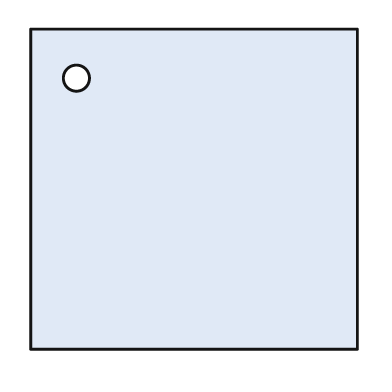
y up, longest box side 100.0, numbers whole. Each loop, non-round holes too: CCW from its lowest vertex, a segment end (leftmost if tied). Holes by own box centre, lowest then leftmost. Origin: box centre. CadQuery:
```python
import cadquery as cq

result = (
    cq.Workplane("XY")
    .moveTo(-50.0, -49.0)
    .lineTo(50.0, -49.0)
    .lineTo(50.0, 49.0)
    .lineTo(-50.0, 49.0)
    .close()
    .moveTo(-36.0, 34.0)
    .circle(4.0)
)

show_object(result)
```